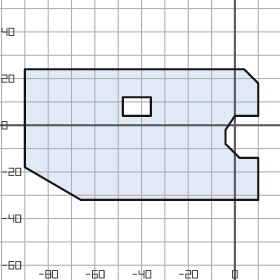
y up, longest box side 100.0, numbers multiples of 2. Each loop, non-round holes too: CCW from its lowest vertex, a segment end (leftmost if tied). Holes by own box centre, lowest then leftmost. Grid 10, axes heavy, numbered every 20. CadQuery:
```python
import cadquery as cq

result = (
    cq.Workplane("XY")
    .moveTo(-66.0, -32.0)
    .lineTo(10.0, -32.0)
    .lineTo(10.0, -14.0)
    .lineTo(2.0, -14.0)
    .lineTo(-4.0, -8.0)
    .lineTo(-4.0, -2.0)
    .lineTo(0.0, 4.0)
    .lineTo(10.0, 4.0)
    .lineTo(10.0, 18.0)
    .lineTo(4.0, 24.0)
    .lineTo(-90.0, 24.0)
    .lineTo(-90.0, -18.0)
    .close()
    .moveTo(-48.0, 4.0)
    .lineTo(-36.0, 4.0)
    .lineTo(-36.0, 12.0)
    .lineTo(-48.0, 12.0)
    .close()
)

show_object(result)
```